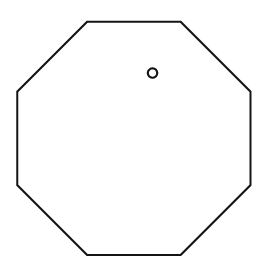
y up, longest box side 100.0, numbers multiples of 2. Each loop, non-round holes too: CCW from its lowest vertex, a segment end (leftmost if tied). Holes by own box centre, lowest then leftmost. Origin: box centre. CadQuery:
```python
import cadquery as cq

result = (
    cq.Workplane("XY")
    .moveTo(-20.0, -50.0)
    .lineTo(20.0, -50.0)
    .lineTo(50.0, -20.0)
    .lineTo(50.0, 20.0)
    .lineTo(20.0, 50.0)
    .lineTo(-20.0, 50.0)
    .lineTo(-50.0, 20.0)
    .lineTo(-50.0, -20.0)
    .close()
    .moveTo(8.0, 28.0)
    .circle(2.0)
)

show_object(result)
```